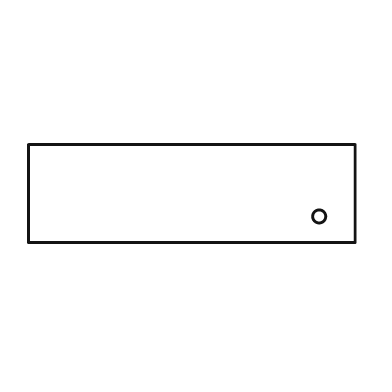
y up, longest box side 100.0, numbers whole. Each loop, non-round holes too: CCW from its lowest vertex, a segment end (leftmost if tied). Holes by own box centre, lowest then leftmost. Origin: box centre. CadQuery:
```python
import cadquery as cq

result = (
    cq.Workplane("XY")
    .moveTo(-50.0, -15.0)
    .lineTo(50.0, -15.0)
    .lineTo(50.0, 15.0)
    .lineTo(-50.0, 15.0)
    .close()
    .moveTo(39.0, -7.0)
    .circle(2.0)
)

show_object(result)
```